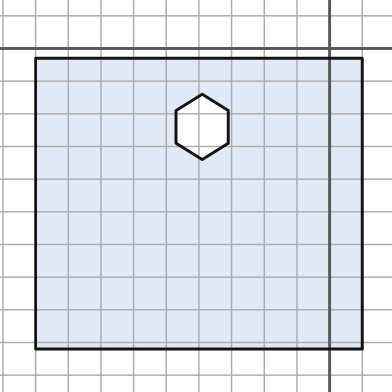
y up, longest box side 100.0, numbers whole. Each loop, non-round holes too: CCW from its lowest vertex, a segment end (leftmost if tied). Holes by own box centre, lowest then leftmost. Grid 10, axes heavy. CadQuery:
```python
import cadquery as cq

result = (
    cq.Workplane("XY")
    .moveTo(-90.0, -92.0)
    .lineTo(10.0, -92.0)
    .lineTo(10.0, -3.0)
    .lineTo(-90.0, -3.0)
    .close()
    .moveTo(-39.0, -34.0)
    .lineTo(-31.0, -29.0)
    .lineTo(-31.0, -19.0)
    .lineTo(-39.0, -14.0)
    .lineTo(-47.0, -19.0)
    .lineTo(-47.0, -29.0)
    .close()
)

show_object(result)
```